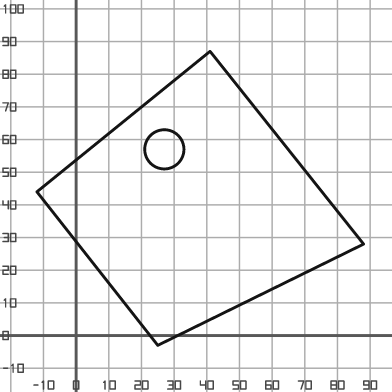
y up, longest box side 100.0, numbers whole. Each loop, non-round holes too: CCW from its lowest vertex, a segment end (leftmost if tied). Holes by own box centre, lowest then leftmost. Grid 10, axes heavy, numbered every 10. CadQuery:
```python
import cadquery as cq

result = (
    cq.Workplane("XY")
    .moveTo(25.0, -3.0)
    .lineTo(88.0, 28.0)
    .lineTo(41.0, 87.0)
    .lineTo(-12.0, 44.0)
    .close()
    .moveTo(27.0, 57.0)
    .circle(6.0)
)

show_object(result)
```